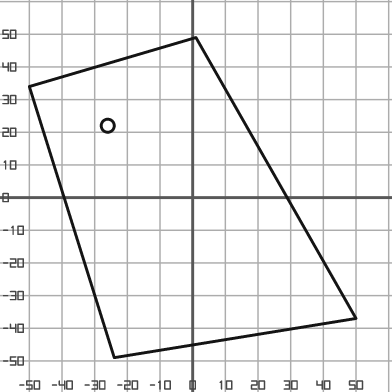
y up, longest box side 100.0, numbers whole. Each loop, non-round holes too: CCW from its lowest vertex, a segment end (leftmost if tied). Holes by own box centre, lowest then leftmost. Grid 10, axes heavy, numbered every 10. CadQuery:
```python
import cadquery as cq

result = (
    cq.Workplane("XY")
    .moveTo(-24.0, -49.0)
    .lineTo(50.0, -37.0)
    .lineTo(1.0, 49.0)
    .lineTo(-50.0, 34.0)
    .close()
    .moveTo(-26.0, 22.0)
    .circle(2.0)
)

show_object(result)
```